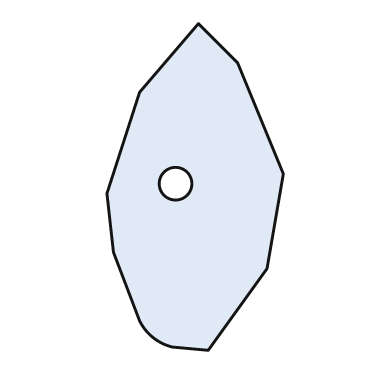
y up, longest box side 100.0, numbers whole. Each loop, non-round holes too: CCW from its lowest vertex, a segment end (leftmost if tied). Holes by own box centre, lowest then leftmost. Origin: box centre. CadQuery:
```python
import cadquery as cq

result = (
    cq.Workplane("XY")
    .moveTo(4.0, -50.0)
    .lineTo(22.0, -25.0)
    .lineTo(27.0, 4.0)
    .lineTo(13.0, 38.0)
    .lineTo(1.0, 50.0)
    .lineTo(-17.0, 29.0)
    .lineTo(-27.0, -2.0)
    .lineTo(-25.0, -20.0)
    .lineTo(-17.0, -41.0)
    .threePointArc((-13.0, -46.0), (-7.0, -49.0))
    .close()
    .moveTo(-6.0, 1.0)
    .circle(5.0)
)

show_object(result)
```